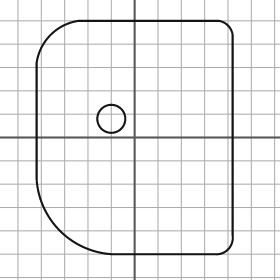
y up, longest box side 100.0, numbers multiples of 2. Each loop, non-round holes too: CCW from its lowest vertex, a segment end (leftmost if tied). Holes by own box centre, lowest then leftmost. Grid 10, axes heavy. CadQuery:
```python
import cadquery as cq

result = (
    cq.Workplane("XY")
    .moveTo(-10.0, -50.0)
    .lineTo(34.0, -50.0)
    .threePointArc((40.0, -48.0), (42.0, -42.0))
    .lineTo(42.0, 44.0)
    .threePointArc((40.0, 48.0), (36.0, 50.0))
    .lineTo(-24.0, 50.0)
    .threePointArc((-36.0, 44.0), (-42.0, 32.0))
    .lineTo(-42.0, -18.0)
    .threePointArc((-32.0, -40.0), (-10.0, -50.0))
    .close()
    .moveTo(-10.0, 8.0)
    .circle(6.0)
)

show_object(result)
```